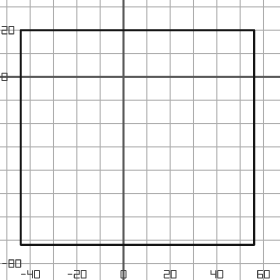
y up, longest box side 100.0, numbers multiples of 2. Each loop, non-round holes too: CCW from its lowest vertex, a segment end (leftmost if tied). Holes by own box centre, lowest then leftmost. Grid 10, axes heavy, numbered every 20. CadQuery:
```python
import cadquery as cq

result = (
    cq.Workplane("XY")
    .moveTo(-44.0, -72.0)
    .lineTo(56.0, -72.0)
    .lineTo(56.0, 20.0)
    .lineTo(-44.0, 20.0)
    .close()
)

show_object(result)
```